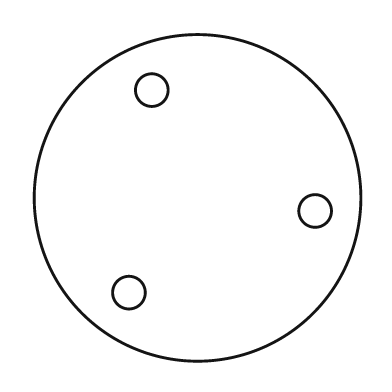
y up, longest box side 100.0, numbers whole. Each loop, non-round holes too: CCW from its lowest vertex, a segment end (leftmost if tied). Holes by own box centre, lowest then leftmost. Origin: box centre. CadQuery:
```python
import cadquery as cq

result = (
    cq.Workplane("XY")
    .moveTo(0.0, 0.0)
    .circle(50.0)
    .moveTo(-21.0, -29.0)
    .circle(5.0)
    .moveTo(36.0, -4.0)
    .circle(5.0)
    .moveTo(-14.0, 33.0)
    .circle(5.0)
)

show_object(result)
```